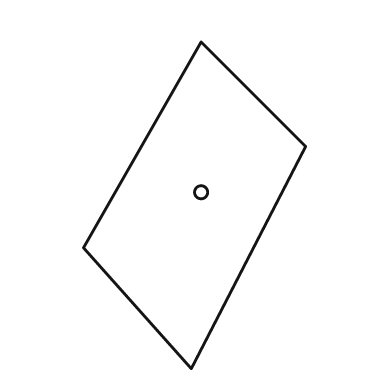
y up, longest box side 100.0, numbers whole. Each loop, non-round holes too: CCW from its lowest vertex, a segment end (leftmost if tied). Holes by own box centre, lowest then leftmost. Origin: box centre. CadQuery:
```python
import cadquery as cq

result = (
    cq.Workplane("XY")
    .moveTo(-1.0, -50.0)
    .lineTo(34.0, 18.0)
    .lineTo(2.0, 50.0)
    .lineTo(-34.0, -13.0)
    .close()
    .moveTo(2.0, 4.0)
    .circle(2.0)
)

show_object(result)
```